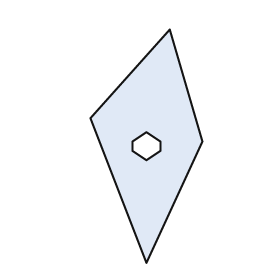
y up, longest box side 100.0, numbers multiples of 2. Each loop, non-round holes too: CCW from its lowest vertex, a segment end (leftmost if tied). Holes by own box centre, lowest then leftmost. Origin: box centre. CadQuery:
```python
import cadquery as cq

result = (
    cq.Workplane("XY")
    .moveTo(0.0, -50.0)
    .lineTo(24.0, 2.0)
    .lineTo(10.0, 50.0)
    .lineTo(-24.0, 12.0)
    .close()
    .moveTo(0.0, -6.0)
    .lineTo(6.0, -2.0)
    .lineTo(6.0, 2.0)
    .lineTo(0.0, 6.0)
    .lineTo(-6.0, 2.0)
    .lineTo(-6.0, -2.0)
    .close()
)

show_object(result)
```